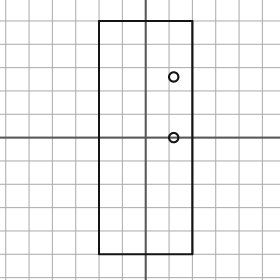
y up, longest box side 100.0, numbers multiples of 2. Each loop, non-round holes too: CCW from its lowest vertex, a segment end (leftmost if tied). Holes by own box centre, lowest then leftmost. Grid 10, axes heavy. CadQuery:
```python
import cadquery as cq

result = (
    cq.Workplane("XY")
    .moveTo(-20.0, -50.0)
    .lineTo(20.0, -50.0)
    .lineTo(20.0, 50.0)
    .lineTo(-20.0, 50.0)
    .close()
    .moveTo(12.0, 0.0)
    .circle(2.0)
    .moveTo(12.0, 26.0)
    .circle(2.0)
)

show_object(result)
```